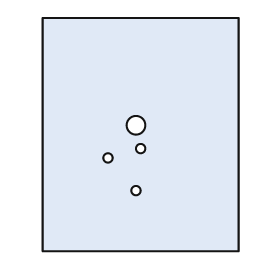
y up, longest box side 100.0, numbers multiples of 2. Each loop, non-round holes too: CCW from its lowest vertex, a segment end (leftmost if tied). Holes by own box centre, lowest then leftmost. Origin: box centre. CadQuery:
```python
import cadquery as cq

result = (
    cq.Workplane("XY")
    .moveTo(-42.0, -50.0)
    .lineTo(42.0, -50.0)
    .lineTo(42.0, 50.0)
    .lineTo(-42.0, 50.0)
    .close()
    .moveTo(-2.0, -24.0)
    .circle(2.0)
    .moveTo(-14.0, -10.0)
    .circle(2.0)
    .moveTo(0.0, -6.0)
    .circle(2.0)
    .moveTo(-2.0, 4.0)
    .circle(4.0)
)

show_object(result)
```